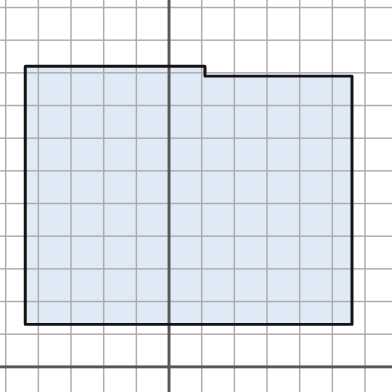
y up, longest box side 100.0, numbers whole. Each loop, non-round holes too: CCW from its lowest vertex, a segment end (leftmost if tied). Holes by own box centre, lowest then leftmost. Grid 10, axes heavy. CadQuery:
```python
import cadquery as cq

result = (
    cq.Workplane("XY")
    .moveTo(-44.0, 13.0)
    .lineTo(56.0, 13.0)
    .lineTo(56.0, 89.0)
    .lineTo(11.0, 89.0)
    .lineTo(11.0, 92.0)
    .lineTo(-44.0, 92.0)
    .close()
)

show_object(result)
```